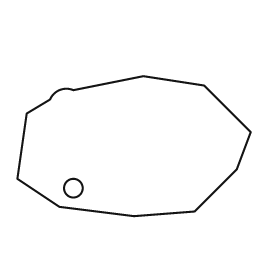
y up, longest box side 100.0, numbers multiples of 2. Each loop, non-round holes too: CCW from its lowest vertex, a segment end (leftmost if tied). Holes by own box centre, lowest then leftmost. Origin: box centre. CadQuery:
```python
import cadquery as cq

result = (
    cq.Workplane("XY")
    .moveTo(0.0, -30.0)
    .lineTo(26.0, -28.0)
    .lineTo(44.0, -10.0)
    .lineTo(50.0, 6.0)
    .lineTo(30.0, 26.0)
    .lineTo(4.0, 30.0)
    .lineTo(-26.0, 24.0)
    .threePointArc((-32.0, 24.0), (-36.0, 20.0))
    .lineTo(-46.0, 14.0)
    .lineTo(-50.0, -14.0)
    .lineTo(-32.0, -26.0)
    .close()
    .moveTo(-26.0, -18.0)
    .circle(4.0)
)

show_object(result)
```